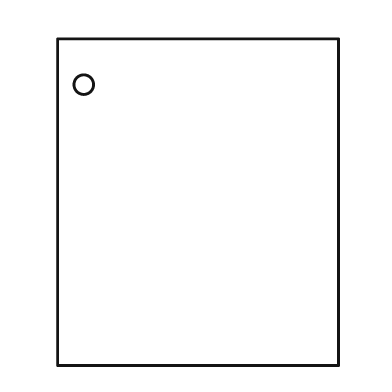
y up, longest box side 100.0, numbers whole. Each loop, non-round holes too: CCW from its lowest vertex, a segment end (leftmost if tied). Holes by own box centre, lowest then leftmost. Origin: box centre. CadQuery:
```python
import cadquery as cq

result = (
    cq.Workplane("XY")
    .moveTo(-43.0, -50.0)
    .lineTo(43.0, -50.0)
    .lineTo(43.0, 50.0)
    .lineTo(-43.0, 50.0)
    .close()
    .moveTo(-35.0, 36.0)
    .circle(3.0)
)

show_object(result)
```